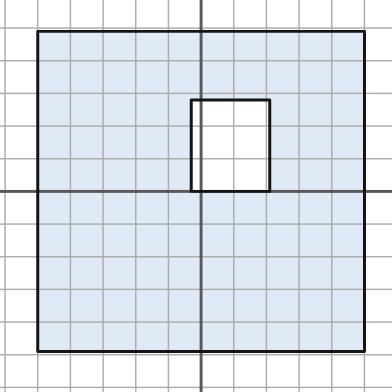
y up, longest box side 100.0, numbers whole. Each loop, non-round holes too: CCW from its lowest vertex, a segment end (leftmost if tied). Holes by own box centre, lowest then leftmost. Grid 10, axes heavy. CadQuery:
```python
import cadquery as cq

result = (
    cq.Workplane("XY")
    .moveTo(-50.0, -49.0)
    .lineTo(50.0, -49.0)
    .lineTo(50.0, 49.0)
    .lineTo(-50.0, 49.0)
    .close()
    .moveTo(-3.0, 0.0)
    .lineTo(21.0, 0.0)
    .lineTo(21.0, 28.0)
    .lineTo(-3.0, 28.0)
    .close()
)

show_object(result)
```